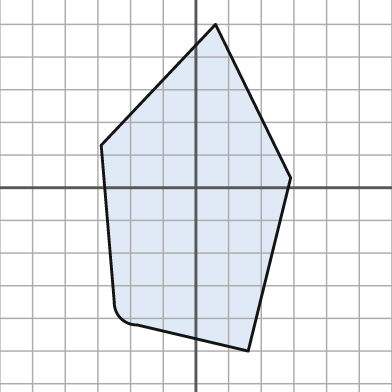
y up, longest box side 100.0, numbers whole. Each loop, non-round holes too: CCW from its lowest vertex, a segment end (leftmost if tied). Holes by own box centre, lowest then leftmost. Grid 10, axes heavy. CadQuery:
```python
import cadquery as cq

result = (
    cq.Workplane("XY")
    .moveTo(16.0, -50.0)
    .lineTo(29.0, 3.0)
    .lineTo(6.0, 50.0)
    .lineTo(-29.0, 13.0)
    .lineTo(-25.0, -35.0)
    .threePointArc((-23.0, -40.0), (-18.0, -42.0))
    .close()
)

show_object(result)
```